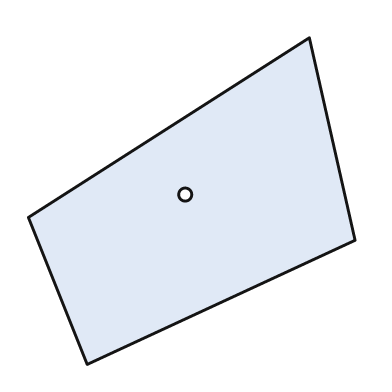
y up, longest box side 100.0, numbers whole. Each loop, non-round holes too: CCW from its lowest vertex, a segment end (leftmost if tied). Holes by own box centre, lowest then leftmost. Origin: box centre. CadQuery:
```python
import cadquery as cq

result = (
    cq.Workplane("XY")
    .moveTo(-32.0, -50.0)
    .lineTo(50.0, -12.0)
    .lineTo(36.0, 50.0)
    .lineTo(-50.0, -5.0)
    .close()
    .moveTo(-2.0, 2.0)
    .circle(2.0)
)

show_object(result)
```